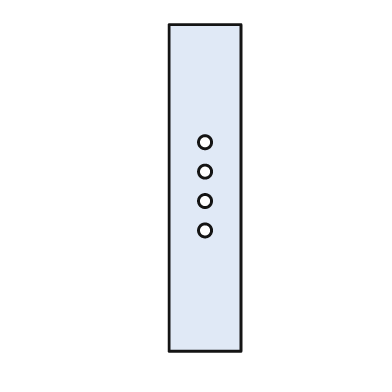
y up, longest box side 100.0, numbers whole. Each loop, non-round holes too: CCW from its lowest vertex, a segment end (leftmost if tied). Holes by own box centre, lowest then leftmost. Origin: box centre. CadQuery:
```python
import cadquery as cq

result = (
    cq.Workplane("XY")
    .moveTo(-11.0, -50.0)
    .lineTo(11.0, -50.0)
    .lineTo(11.0, 50.0)
    .lineTo(-11.0, 50.0)
    .close()
    .moveTo(0.0, -13.0)
    .circle(2.0)
    .moveTo(0.0, -4.0)
    .circle(2.0)
    .moveTo(0.0, 5.0)
    .circle(2.0)
    .moveTo(0.0, 14.0)
    .circle(2.0)
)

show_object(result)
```